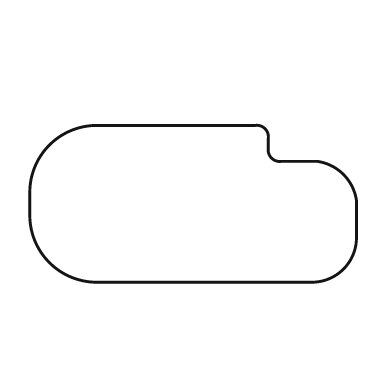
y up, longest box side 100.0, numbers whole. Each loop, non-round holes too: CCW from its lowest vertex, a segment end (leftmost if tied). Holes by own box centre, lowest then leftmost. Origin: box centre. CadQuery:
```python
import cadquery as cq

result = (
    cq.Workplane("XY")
    .moveTo(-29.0, -24.0)
    .lineTo(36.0, -24.0)
    .threePointArc((46.0, -20.0), (50.0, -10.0))
    .lineTo(50.0, 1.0)
    .threePointArc((46.0, 9.0), (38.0, 13.0))
    .lineTo(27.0, 13.0)
    .threePointArc((24.0, 14.0), (23.0, 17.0))
    .lineTo(23.0, 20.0)
    .threePointArc((22.0, 23.0), (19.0, 24.0))
    .lineTo(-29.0, 24.0)
    .threePointArc((-44.0, 18.0), (-50.0, 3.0))
    .lineTo(-50.0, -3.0)
    .threePointArc((-44.0, -18.0), (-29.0, -24.0))
    .close()
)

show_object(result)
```